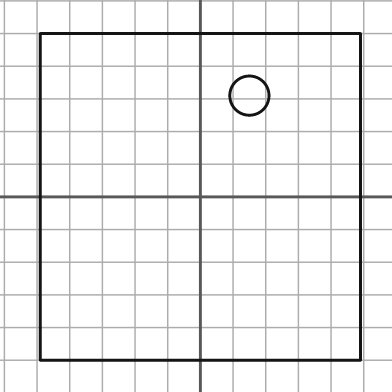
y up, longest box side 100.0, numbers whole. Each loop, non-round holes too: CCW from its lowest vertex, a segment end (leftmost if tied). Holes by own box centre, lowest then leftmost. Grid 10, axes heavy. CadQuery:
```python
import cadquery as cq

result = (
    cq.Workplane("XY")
    .moveTo(-49.0, -50.0)
    .lineTo(49.0, -50.0)
    .lineTo(49.0, 50.0)
    .lineTo(-49.0, 50.0)
    .close()
    .moveTo(15.0, 31.0)
    .circle(6.0)
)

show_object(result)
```